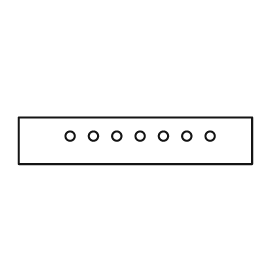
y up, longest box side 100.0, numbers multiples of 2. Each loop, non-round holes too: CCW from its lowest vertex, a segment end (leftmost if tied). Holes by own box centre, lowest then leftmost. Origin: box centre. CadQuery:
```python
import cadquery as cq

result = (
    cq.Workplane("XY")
    .moveTo(-50.0, -10.0)
    .lineTo(50.0, -10.0)
    .lineTo(50.0, 10.0)
    .lineTo(-50.0, 10.0)
    .close()
    .moveTo(-28.0, 2.0)
    .circle(2.0)
    .moveTo(-18.0, 2.0)
    .circle(2.0)
    .moveTo(-8.0, 2.0)
    .circle(2.0)
    .moveTo(2.0, 2.0)
    .circle(2.0)
    .moveTo(12.0, 2.0)
    .circle(2.0)
    .moveTo(22.0, 2.0)
    .circle(2.0)
    .moveTo(32.0, 2.0)
    .circle(2.0)
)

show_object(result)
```